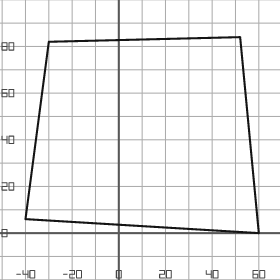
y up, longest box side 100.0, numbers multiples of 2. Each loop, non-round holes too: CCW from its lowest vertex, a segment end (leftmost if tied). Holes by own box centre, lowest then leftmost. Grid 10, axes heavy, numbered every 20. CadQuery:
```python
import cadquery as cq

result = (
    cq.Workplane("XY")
    .moveTo(60.0, 0.0)
    .lineTo(52.0, 84.0)
    .lineTo(-30.0, 82.0)
    .lineTo(-40.0, 6.0)
    .close()
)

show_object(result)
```